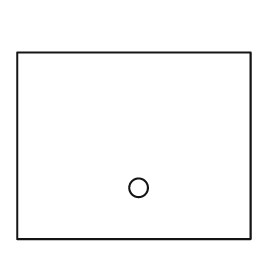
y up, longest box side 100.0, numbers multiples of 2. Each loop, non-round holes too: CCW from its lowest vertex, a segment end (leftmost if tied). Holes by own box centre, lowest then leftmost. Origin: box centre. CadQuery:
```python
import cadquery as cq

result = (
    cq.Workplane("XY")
    .moveTo(-50.0, -40.0)
    .lineTo(50.0, -40.0)
    .lineTo(50.0, 40.0)
    .lineTo(-50.0, 40.0)
    .close()
    .moveTo(2.0, -18.0)
    .circle(4.0)
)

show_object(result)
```